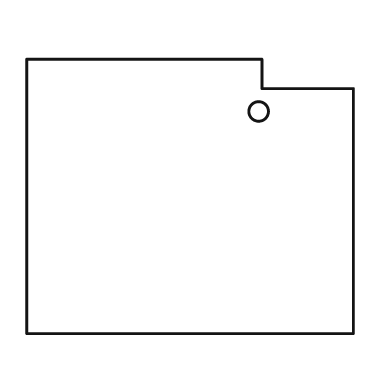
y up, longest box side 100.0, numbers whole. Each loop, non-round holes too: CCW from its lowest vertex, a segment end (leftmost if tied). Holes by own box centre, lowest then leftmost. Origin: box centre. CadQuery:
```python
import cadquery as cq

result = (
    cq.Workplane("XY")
    .moveTo(-50.0, -42.0)
    .lineTo(50.0, -42.0)
    .lineTo(50.0, 33.0)
    .lineTo(22.0, 33.0)
    .lineTo(22.0, 42.0)
    .lineTo(-50.0, 42.0)
    .close()
    .moveTo(21.0, 26.0)
    .circle(3.0)
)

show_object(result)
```